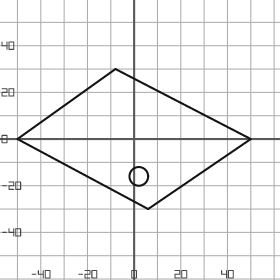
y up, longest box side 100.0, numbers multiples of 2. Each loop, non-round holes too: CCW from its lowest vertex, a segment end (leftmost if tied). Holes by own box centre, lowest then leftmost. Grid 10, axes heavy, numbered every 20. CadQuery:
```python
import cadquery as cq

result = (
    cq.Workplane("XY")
    .moveTo(6.0, -30.0)
    .lineTo(50.0, 0.0)
    .lineTo(-8.0, 30.0)
    .lineTo(-50.0, 0.0)
    .close()
    .moveTo(2.0, -16.0)
    .circle(4.0)
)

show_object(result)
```